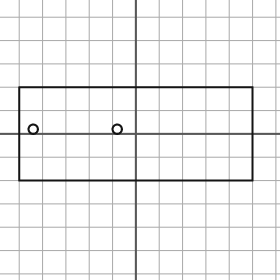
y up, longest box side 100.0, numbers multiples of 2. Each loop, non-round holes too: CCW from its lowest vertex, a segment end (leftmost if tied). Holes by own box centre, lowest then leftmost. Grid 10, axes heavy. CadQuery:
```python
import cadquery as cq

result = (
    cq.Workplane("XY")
    .moveTo(-50.0, -20.0)
    .lineTo(50.0, -20.0)
    .lineTo(50.0, 20.0)
    .lineTo(-50.0, 20.0)
    .close()
    .moveTo(-44.0, 2.0)
    .circle(2.0)
    .moveTo(-8.0, 2.0)
    .circle(2.0)
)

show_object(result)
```